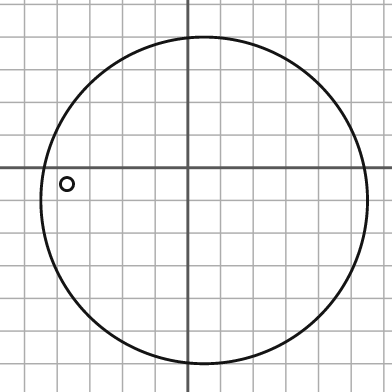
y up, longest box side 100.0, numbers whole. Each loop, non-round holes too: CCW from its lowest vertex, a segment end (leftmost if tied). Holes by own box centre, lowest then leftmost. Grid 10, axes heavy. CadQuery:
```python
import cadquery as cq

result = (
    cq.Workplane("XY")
    .moveTo(5.0, -10.0)
    .circle(50.0)
    .moveTo(-37.0, -5.0)
    .circle(2.0)
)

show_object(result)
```